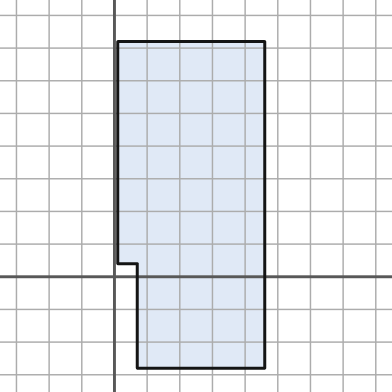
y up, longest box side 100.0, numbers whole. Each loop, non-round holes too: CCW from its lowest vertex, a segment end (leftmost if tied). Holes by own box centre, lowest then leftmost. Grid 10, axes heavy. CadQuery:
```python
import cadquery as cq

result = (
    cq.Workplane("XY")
    .moveTo(7.0, -28.0)
    .lineTo(46.0, -28.0)
    .lineTo(46.0, 72.0)
    .lineTo(1.0, 72.0)
    .lineTo(1.0, 4.0)
    .lineTo(7.0, 4.0)
    .close()
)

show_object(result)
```